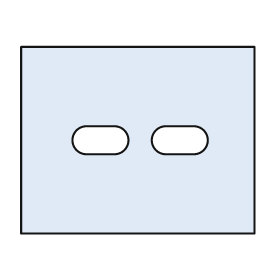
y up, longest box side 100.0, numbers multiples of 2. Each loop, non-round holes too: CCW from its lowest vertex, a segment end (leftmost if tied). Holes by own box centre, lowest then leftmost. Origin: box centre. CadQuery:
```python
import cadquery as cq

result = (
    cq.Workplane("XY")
    .moveTo(-50.0, -40.0)
    .lineTo(50.0, -40.0)
    .lineTo(50.0, 40.0)
    .lineTo(-50.0, 40.0)
    .close()
    .moveTo(-22.0, -6.0)
    .lineTo(-10.0, -6.0)
    .threePointArc((-4.0, 0.0), (-10.0, 6.0))
    .lineTo(-22.0, 6.0)
    .threePointArc((-28.0, 0.0), (-22.0, -6.0))
    .close()
    .moveTo(12.0, -6.0)
    .lineTo(24.0, -6.0)
    .threePointArc((30.0, 0.0), (24.0, 6.0))
    .lineTo(12.0, 6.0)
    .threePointArc((6.0, 0.0), (12.0, -6.0))
    .close()
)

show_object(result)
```